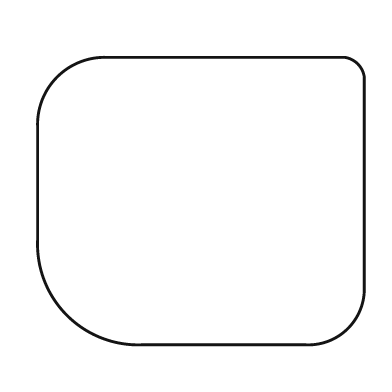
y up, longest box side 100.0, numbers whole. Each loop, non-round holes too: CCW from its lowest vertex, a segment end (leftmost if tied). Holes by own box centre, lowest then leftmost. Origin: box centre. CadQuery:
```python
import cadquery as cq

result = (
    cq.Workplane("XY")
    .moveTo(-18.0, -44.0)
    .lineTo(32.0, -44.0)
    .threePointArc((45.0, -39.0), (50.0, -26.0))
    .lineTo(50.0, 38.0)
    .threePointArc((48.0, 42.0), (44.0, 44.0))
    .lineTo(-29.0, 44.0)
    .threePointArc((-44.0, 38.0), (-50.0, 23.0))
    .lineTo(-50.0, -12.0)
    .threePointArc((-41.0, -35.0), (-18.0, -44.0))
    .close()
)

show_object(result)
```